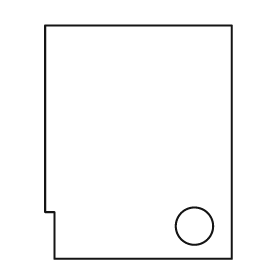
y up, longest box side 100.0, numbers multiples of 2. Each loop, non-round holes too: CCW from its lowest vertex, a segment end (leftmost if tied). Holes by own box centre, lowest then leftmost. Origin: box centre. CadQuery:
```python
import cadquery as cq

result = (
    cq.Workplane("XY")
    .moveTo(-36.0, -50.0)
    .lineTo(40.0, -50.0)
    .lineTo(40.0, 50.0)
    .lineTo(-40.0, 50.0)
    .lineTo(-40.0, -30.0)
    .lineTo(-36.0, -30.0)
    .close()
    .moveTo(24.0, -36.0)
    .circle(8.0)
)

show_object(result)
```